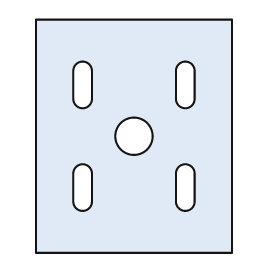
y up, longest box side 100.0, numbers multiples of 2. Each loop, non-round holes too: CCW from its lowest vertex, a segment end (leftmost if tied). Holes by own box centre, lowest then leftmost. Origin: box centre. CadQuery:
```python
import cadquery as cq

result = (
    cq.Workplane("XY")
    .moveTo(-42.0, -50.0)
    .lineTo(42.0, -50.0)
    .lineTo(42.0, 50.0)
    .lineTo(-42.0, 50.0)
    .close()
    .moveTo(-26.0, -28.0)
    .threePointArc((-22.0, -32.0), (-18.0, -28.0))
    .lineTo(-18.0, -16.0)
    .threePointArc((-22.0, -12.0), (-26.0, -16.0))
    .close()
    .moveTo(18.0, -28.0)
    .threePointArc((22.0, -32.0), (26.0, -28.0))
    .lineTo(26.0, -16.0)
    .threePointArc((22.0, -12.0), (18.0, -16.0))
    .close()
    .moveTo(0.0, 0.0)
    .circle(8.0)
    .moveTo(-26.0, 16.0)
    .threePointArc((-22.0, 12.0), (-18.0, 16.0))
    .lineTo(-18.0, 28.0)
    .threePointArc((-22.0, 32.0), (-26.0, 28.0))
    .close()
    .moveTo(18.0, 16.0)
    .threePointArc((22.0, 12.0), (26.0, 16.0))
    .lineTo(26.0, 28.0)
    .threePointArc((22.0, 32.0), (18.0, 28.0))
    .close()
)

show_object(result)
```